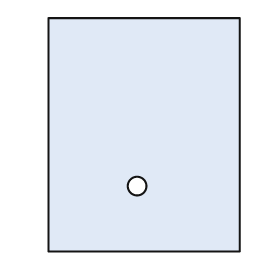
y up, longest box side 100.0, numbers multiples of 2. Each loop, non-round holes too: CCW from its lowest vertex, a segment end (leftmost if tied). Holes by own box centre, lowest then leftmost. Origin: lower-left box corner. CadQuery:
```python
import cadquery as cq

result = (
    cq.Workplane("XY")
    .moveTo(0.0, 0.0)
    .lineTo(82.0, 0.0)
    .lineTo(82.0, 100.0)
    .lineTo(0.0, 100.0)
    .close()
    .moveTo(38.0, 28.0)
    .circle(4.0)
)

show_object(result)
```